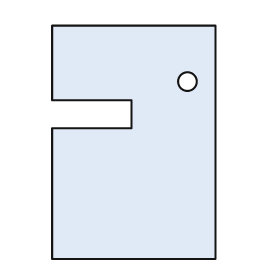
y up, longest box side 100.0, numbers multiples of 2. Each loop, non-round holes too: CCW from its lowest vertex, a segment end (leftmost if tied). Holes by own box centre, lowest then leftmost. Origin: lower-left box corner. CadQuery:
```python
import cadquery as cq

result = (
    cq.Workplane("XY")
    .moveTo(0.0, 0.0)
    .lineTo(70.0, 0.0)
    .lineTo(70.0, 100.0)
    .lineTo(0.0, 100.0)
    .lineTo(0.0, 68.0)
    .lineTo(34.0, 68.0)
    .lineTo(34.0, 56.0)
    .lineTo(0.0, 56.0)
    .close()
    .moveTo(58.0, 76.0)
    .circle(4.0)
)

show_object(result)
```